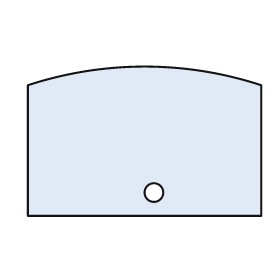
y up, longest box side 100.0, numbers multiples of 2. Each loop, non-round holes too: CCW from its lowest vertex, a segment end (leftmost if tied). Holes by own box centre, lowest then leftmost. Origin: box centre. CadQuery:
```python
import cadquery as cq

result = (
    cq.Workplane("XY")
    .moveTo(-50.0, -32.0)
    .lineTo(50.0, -32.0)
    .lineTo(50.0, 24.0)
    .threePointArc((0.0, 32.0), (-50.0, 24.0))
    .close()
    .moveTo(4.0, -22.0)
    .circle(4.0)
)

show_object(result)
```